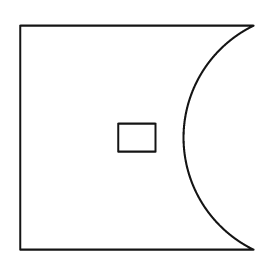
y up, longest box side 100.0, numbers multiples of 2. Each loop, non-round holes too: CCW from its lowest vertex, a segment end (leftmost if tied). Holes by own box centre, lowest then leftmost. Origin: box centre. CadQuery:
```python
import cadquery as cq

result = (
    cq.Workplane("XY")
    .moveTo(-50.0, -48.0)
    .lineTo(50.0, -48.0)
    .threePointArc((20.0, 0.0), (50.0, 48.0))
    .lineTo(-50.0, 48.0)
    .close()
    .moveTo(-8.0, -6.0)
    .lineTo(8.0, -6.0)
    .lineTo(8.0, 6.0)
    .lineTo(-8.0, 6.0)
    .close()
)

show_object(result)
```